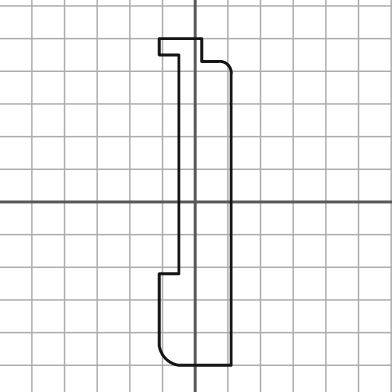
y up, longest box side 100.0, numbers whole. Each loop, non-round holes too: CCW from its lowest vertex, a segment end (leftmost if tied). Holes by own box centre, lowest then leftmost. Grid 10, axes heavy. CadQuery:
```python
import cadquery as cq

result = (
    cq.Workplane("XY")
    .moveTo(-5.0, -50.0)
    .lineTo(11.0, -50.0)
    .lineTo(11.0, 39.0)
    .threePointArc((10.0, 42.0), (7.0, 43.0))
    .lineTo(2.0, 43.0)
    .lineTo(2.0, 50.0)
    .lineTo(-11.0, 50.0)
    .lineTo(-11.0, 45.0)
    .lineTo(-5.0, 45.0)
    .lineTo(-5.0, -22.0)
    .lineTo(-11.0, -22.0)
    .lineTo(-11.0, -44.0)
    .threePointArc((-9.0, -48.0), (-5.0, -50.0))
    .close()
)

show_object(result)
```